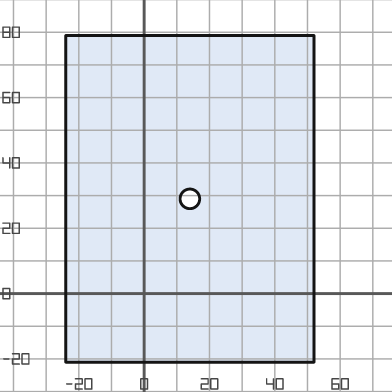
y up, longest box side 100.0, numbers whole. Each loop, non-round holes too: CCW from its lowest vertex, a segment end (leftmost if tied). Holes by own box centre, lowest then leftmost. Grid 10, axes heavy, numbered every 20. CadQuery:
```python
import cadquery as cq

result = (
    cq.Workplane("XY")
    .moveTo(-24.0, -21.0)
    .lineTo(52.0, -21.0)
    .lineTo(52.0, 79.0)
    .lineTo(-24.0, 79.0)
    .close()
    .moveTo(14.0, 29.0)
    .circle(3.0)
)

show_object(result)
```